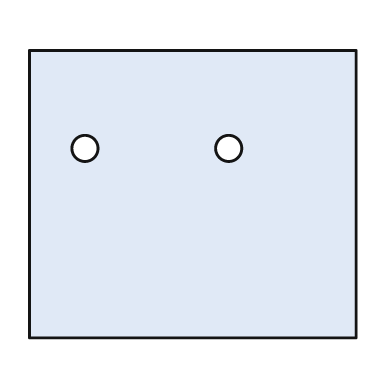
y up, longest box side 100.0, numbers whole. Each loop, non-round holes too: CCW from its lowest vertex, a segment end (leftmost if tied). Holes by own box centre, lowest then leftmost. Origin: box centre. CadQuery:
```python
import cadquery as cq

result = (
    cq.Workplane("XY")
    .moveTo(-50.0, -44.0)
    .lineTo(50.0, -44.0)
    .lineTo(50.0, 44.0)
    .lineTo(-50.0, 44.0)
    .close()
    .moveTo(-33.0, 14.0)
    .circle(4.0)
    .moveTo(11.0, 14.0)
    .circle(4.0)
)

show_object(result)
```